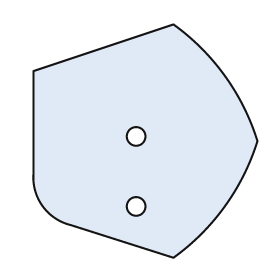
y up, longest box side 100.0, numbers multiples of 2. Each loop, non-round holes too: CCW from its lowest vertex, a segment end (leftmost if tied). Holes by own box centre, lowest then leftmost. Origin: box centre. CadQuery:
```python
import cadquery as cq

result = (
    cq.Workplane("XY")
    .moveTo(12.0, -50.0)
    .threePointArc((34.0, -28.0), (48.0, 0.0))
    .threePointArc((34.0, 28.0), (12.0, 50.0))
    .lineTo(-48.0, 30.0)
    .lineTo(-48.0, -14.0)
    .threePointArc((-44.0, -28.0), (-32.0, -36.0))
    .close()
    .moveTo(-4.0, -28.0)
    .circle(4.0)
    .moveTo(-4.0, 2.0)
    .circle(4.0)
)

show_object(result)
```